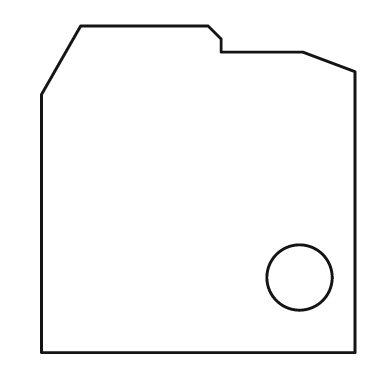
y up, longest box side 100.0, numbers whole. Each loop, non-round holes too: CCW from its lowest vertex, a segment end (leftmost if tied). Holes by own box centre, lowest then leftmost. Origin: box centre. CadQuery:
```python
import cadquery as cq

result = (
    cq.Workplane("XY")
    .moveTo(-48.0, -50.0)
    .lineTo(48.0, -50.0)
    .lineTo(48.0, 36.0)
    .lineTo(32.0, 42.0)
    .lineTo(7.0, 42.0)
    .lineTo(7.0, 46.0)
    .lineTo(3.0, 50.0)
    .lineTo(-36.0, 50.0)
    .lineTo(-48.0, 29.0)
    .close()
    .moveTo(31.0, -27.0)
    .circle(10.0)
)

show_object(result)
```